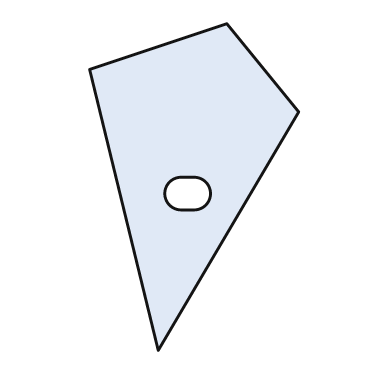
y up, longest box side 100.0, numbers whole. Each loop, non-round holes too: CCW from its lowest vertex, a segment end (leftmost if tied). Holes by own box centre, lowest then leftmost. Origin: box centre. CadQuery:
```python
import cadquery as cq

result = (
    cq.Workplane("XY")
    .moveTo(-11.0, -50.0)
    .lineTo(32.0, 23.0)
    .lineTo(10.0, 50.0)
    .lineTo(-32.0, 36.0)
    .close()
    .moveTo(-4.0, -7.0)
    .lineTo(0.0, -7.0)
    .threePointArc((5.0, -2.0), (0.0, 3.0))
    .lineTo(-4.0, 3.0)
    .threePointArc((-9.0, -2.0), (-4.0, -7.0))
    .close()
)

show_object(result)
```